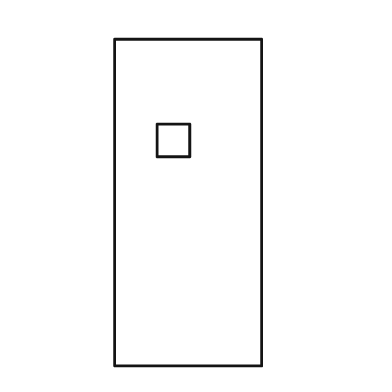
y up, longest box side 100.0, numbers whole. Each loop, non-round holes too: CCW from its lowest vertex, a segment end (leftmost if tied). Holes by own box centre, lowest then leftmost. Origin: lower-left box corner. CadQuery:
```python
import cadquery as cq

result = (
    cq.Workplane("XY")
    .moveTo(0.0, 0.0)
    .lineTo(45.0, 0.0)
    .lineTo(45.0, 100.0)
    .lineTo(0.0, 100.0)
    .close()
    .moveTo(13.0, 64.0)
    .lineTo(23.0, 64.0)
    .lineTo(23.0, 74.0)
    .lineTo(13.0, 74.0)
    .close()
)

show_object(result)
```